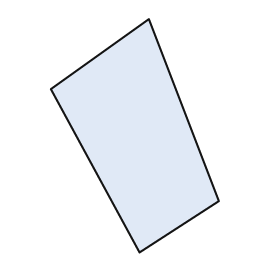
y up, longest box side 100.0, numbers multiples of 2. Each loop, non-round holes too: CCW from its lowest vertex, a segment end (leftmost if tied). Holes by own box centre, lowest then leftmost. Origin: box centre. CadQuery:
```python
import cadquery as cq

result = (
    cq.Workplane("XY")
    .moveTo(2.0, -50.0)
    .lineTo(36.0, -28.0)
    .lineTo(6.0, 50.0)
    .lineTo(-36.0, 20.0)
    .close()
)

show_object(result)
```